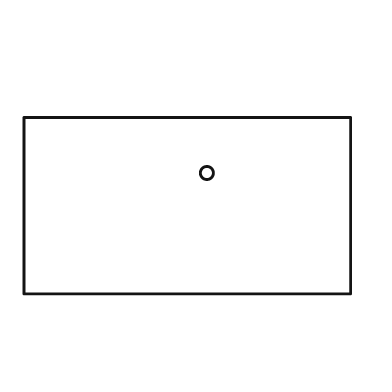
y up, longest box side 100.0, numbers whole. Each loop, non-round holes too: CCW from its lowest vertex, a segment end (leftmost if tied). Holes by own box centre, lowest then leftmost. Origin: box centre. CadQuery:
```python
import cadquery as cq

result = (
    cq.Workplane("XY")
    .moveTo(-50.0, -27.0)
    .lineTo(50.0, -27.0)
    .lineTo(50.0, 27.0)
    .lineTo(-50.0, 27.0)
    .close()
    .moveTo(6.0, 10.0)
    .circle(2.0)
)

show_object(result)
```